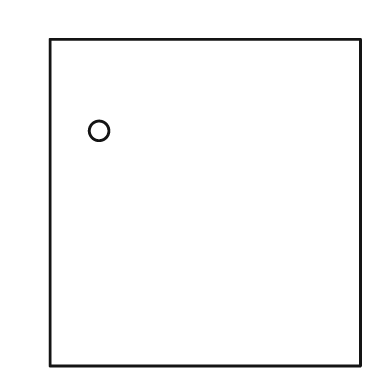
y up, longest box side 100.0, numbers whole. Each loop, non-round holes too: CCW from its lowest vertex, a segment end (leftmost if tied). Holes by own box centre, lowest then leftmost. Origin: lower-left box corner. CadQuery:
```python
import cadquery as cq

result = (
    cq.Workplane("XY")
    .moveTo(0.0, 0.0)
    .lineTo(95.0, 0.0)
    .lineTo(95.0, 100.0)
    .lineTo(0.0, 100.0)
    .close()
    .moveTo(15.0, 72.0)
    .circle(3.0)
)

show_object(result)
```